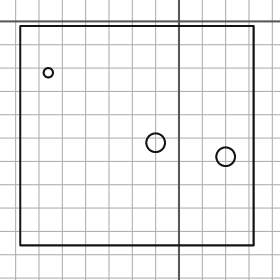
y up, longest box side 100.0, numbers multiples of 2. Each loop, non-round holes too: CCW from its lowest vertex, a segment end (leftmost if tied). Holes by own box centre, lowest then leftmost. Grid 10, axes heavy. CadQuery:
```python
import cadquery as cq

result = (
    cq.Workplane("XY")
    .moveTo(-68.0, -96.0)
    .lineTo(32.0, -96.0)
    .lineTo(32.0, -2.0)
    .lineTo(-68.0, -2.0)
    .close()
    .moveTo(20.0, -58.0)
    .circle(4.0)
    .moveTo(-10.0, -52.0)
    .circle(4.0)
    .moveTo(-56.0, -22.0)
    .circle(2.0)
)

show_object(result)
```